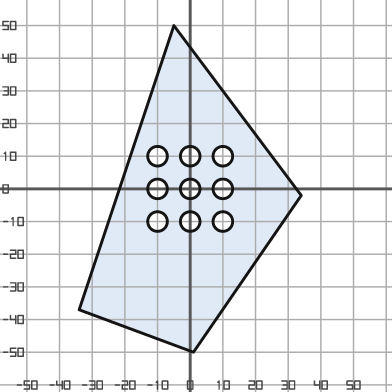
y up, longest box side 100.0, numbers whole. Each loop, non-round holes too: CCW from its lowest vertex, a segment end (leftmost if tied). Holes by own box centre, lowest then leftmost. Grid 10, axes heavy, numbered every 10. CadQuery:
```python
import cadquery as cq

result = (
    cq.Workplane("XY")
    .moveTo(1.0, -50.0)
    .lineTo(34.0, -2.0)
    .lineTo(-5.0, 50.0)
    .lineTo(-34.0, -37.0)
    .close()
    .moveTo(-10.0, -10.0)
    .circle(3.0)
    .moveTo(0.0, -10.0)
    .circle(3.0)
    .moveTo(10.0, -10.0)
    .circle(3.0)
    .moveTo(-10.0, 0.0)
    .circle(3.0)
    .moveTo(0.0, 0.0)
    .circle(3.0)
    .moveTo(10.0, 0.0)
    .circle(3.0)
    .moveTo(-10.0, 10.0)
    .circle(3.0)
    .moveTo(0.0, 10.0)
    .circle(3.0)
    .moveTo(10.0, 10.0)
    .circle(3.0)
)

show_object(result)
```